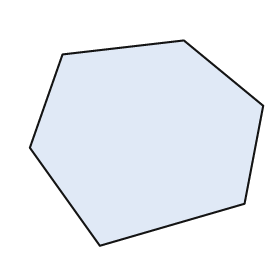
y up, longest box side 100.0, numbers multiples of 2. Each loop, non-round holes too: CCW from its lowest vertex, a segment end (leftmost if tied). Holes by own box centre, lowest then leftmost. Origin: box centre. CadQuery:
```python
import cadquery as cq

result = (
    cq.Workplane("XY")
    .moveTo(-20.0, -44.0)
    .lineTo(42.0, -26.0)
    .lineTo(50.0, 16.0)
    .lineTo(16.0, 44.0)
    .lineTo(-36.0, 38.0)
    .lineTo(-50.0, -2.0)
    .close()
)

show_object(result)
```